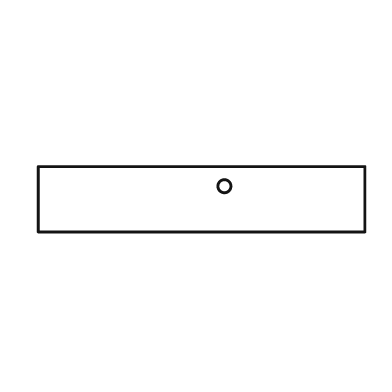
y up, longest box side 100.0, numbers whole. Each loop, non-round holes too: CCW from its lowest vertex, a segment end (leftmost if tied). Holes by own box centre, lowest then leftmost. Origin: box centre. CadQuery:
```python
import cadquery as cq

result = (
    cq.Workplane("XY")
    .moveTo(-50.0, -10.0)
    .lineTo(50.0, -10.0)
    .lineTo(50.0, 10.0)
    .lineTo(-50.0, 10.0)
    .close()
    .moveTo(7.0, 4.0)
    .circle(2.0)
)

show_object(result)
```